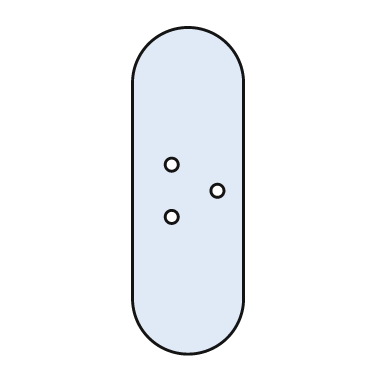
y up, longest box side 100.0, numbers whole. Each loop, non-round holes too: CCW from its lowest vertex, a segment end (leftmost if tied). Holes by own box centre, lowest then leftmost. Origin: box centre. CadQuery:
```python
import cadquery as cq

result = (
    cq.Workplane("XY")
    .moveTo(-17.0, -33.0)
    .threePointArc((0.0, -50.0), (17.0, -33.0))
    .lineTo(17.0, 33.0)
    .threePointArc((0.0, 50.0), (-17.0, 33.0))
    .close()
    .moveTo(-5.0, -8.0)
    .circle(2.0)
    .moveTo(9.0, 0.0)
    .circle(2.0)
    .moveTo(-5.0, 8.0)
    .circle(2.0)
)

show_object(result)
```